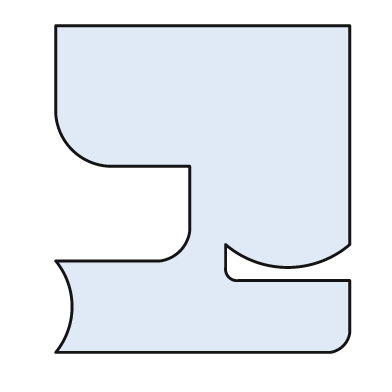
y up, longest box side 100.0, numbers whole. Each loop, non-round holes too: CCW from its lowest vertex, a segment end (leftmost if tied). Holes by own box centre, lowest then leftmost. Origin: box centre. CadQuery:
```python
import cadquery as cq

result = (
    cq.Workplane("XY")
    .moveTo(-45.0, -50.0)
    .lineTo(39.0, -50.0)
    .threePointArc((43.0, -48.0), (45.0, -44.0))
    .lineTo(45.0, -28.0)
    .lineTo(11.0, -28.0)
    .threePointArc((8.0, -27.0), (7.0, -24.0))
    .lineTo(7.0, -17.0)
    .threePointArc((26.0, -24.0), (45.0, -17.0))
    .lineTo(45.0, 50.0)
    .lineTo(-45.0, 50.0)
    .lineTo(-45.0, 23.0)
    .threePointArc((-40.0, 12.0), (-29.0, 7.0))
    .lineTo(-4.0, 7.0)
    .lineTo(-4.0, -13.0)
    .threePointArc((-7.0, -19.0), (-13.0, -22.0))
    .lineTo(-45.0, -22.0)
    .threePointArc((-40.0, -36.0), (-45.0, -50.0))
    .close()
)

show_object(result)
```